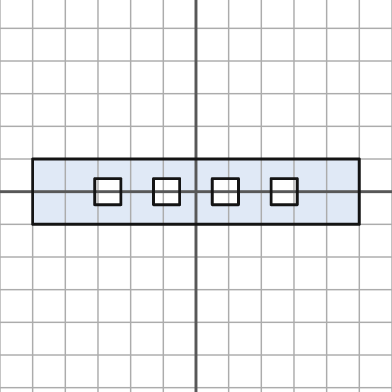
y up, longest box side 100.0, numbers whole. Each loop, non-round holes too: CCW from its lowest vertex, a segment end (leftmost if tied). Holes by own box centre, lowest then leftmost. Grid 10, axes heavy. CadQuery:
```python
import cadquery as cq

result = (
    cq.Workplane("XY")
    .moveTo(-50.0, -10.0)
    .lineTo(50.0, -10.0)
    .lineTo(50.0, 10.0)
    .lineTo(-50.0, 10.0)
    .close()
    .moveTo(-31.0, -4.0)
    .lineTo(-23.0, -4.0)
    .lineTo(-23.0, 4.0)
    .lineTo(-31.0, 4.0)
    .close()
    .moveTo(-13.0, -4.0)
    .lineTo(-5.0, -4.0)
    .lineTo(-5.0, 4.0)
    .lineTo(-13.0, 4.0)
    .close()
    .moveTo(5.0, -4.0)
    .lineTo(13.0, -4.0)
    .lineTo(13.0, 4.0)
    .lineTo(5.0, 4.0)
    .close()
    .moveTo(23.0, -4.0)
    .lineTo(31.0, -4.0)
    .lineTo(31.0, 4.0)
    .lineTo(23.0, 4.0)
    .close()
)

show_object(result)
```